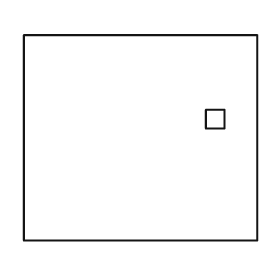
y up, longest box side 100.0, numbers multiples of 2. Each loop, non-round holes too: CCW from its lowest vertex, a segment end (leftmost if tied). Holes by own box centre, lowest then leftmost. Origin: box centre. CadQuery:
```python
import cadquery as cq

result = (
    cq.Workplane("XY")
    .moveTo(-50.0, -44.0)
    .lineTo(50.0, -44.0)
    .lineTo(50.0, 44.0)
    .lineTo(-50.0, 44.0)
    .close()
    .moveTo(28.0, 4.0)
    .lineTo(36.0, 4.0)
    .lineTo(36.0, 12.0)
    .lineTo(28.0, 12.0)
    .close()
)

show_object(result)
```